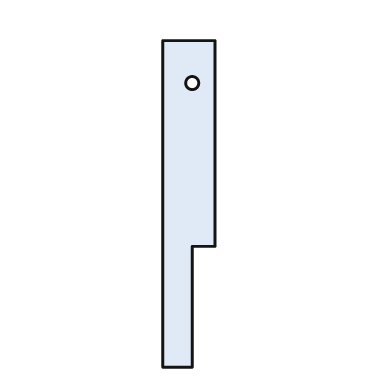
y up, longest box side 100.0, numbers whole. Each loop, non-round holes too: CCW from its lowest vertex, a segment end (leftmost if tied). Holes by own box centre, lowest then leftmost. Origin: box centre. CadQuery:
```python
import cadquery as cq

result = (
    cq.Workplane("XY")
    .moveTo(-8.0, -50.0)
    .lineTo(1.0, -50.0)
    .lineTo(1.0, -13.0)
    .lineTo(8.0, -13.0)
    .lineTo(8.0, 50.0)
    .lineTo(-8.0, 50.0)
    .close()
    .moveTo(1.0, 37.0)
    .circle(2.0)
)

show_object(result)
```